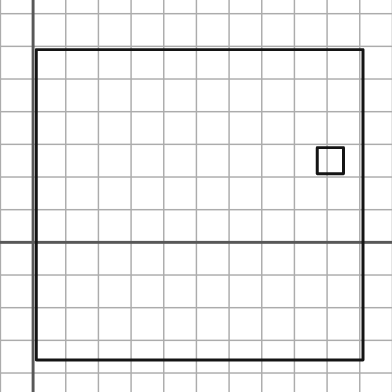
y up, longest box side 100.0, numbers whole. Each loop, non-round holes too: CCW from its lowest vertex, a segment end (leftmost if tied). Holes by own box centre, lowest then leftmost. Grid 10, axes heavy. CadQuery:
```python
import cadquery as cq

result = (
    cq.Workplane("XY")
    .moveTo(1.0, -36.0)
    .lineTo(101.0, -36.0)
    .lineTo(101.0, 59.0)
    .lineTo(1.0, 59.0)
    .close()
    .moveTo(87.0, 21.0)
    .lineTo(95.0, 21.0)
    .lineTo(95.0, 29.0)
    .lineTo(87.0, 29.0)
    .close()
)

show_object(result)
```